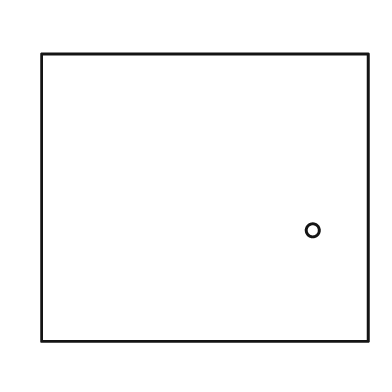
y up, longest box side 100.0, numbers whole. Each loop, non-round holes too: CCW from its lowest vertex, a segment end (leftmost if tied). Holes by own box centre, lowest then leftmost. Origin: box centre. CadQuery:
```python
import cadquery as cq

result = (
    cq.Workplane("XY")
    .moveTo(-50.0, -44.0)
    .lineTo(50.0, -44.0)
    .lineTo(50.0, 44.0)
    .lineTo(-50.0, 44.0)
    .close()
    .moveTo(33.0, -10.0)
    .circle(2.0)
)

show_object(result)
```